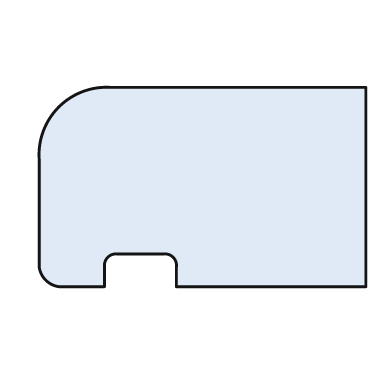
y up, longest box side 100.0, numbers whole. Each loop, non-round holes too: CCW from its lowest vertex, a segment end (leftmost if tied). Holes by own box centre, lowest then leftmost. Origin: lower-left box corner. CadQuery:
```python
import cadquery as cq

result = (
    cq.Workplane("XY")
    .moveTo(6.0, 0.0)
    .lineTo(20.0, 0.0)
    .lineTo(20.0, 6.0)
    .threePointArc((21.0, 9.0), (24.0, 10.0))
    .lineTo(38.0, 10.0)
    .threePointArc((41.0, 9.0), (42.0, 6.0))
    .lineTo(42.0, 0.0)
    .lineTo(100.0, 0.0)
    .lineTo(100.0, 61.0)
    .lineTo(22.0, 61.0)
    .threePointArc((6.0, 55.0), (0.0, 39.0))
    .lineTo(0.0, 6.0)
    .threePointArc((2.0, 2.0), (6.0, 0.0))
    .close()
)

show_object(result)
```